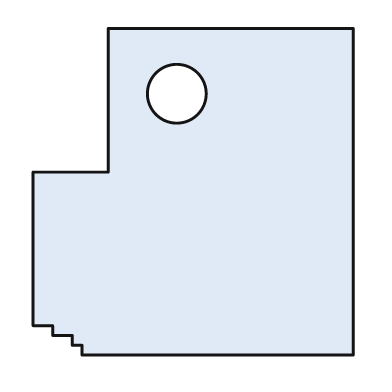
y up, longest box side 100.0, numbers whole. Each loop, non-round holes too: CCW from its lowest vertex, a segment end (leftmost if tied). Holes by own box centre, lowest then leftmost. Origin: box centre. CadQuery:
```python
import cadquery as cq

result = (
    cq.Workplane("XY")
    .moveTo(-34.0, -50.0)
    .lineTo(49.0, -50.0)
    .lineTo(49.0, 50.0)
    .lineTo(-26.0, 50.0)
    .lineTo(-26.0, 6.0)
    .lineTo(-49.0, 6.0)
    .lineTo(-49.0, -41.0)
    .lineTo(-43.0, -41.0)
    .lineTo(-43.0, -44.0)
    .lineTo(-37.0, -44.0)
    .lineTo(-37.0, -47.0)
    .lineTo(-34.0, -47.0)
    .close()
    .moveTo(-5.0, 30.0)
    .circle(9.0)
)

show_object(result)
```